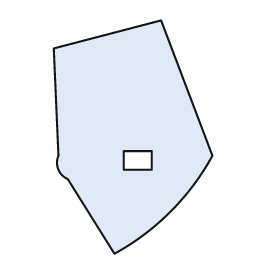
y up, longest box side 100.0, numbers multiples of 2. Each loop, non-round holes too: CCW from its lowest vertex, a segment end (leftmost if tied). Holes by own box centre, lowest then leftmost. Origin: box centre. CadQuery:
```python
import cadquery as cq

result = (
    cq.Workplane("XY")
    .moveTo(-8.0, -50.0)
    .threePointArc((16.0, -32.0), (34.0, -8.0))
    .lineTo(12.0, 50.0)
    .lineTo(-34.0, 38.0)
    .lineTo(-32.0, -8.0)
    .threePointArc((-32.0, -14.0), (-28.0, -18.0))
    .close()
    .moveTo(-4.0, -14.0)
    .lineTo(8.0, -14.0)
    .lineTo(8.0, -6.0)
    .lineTo(-4.0, -6.0)
    .close()
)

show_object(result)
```